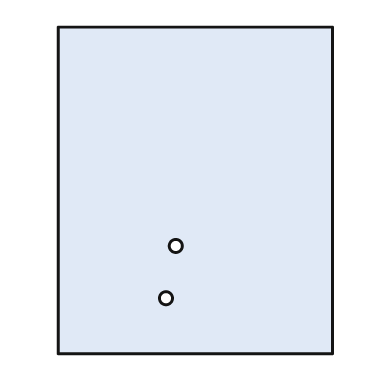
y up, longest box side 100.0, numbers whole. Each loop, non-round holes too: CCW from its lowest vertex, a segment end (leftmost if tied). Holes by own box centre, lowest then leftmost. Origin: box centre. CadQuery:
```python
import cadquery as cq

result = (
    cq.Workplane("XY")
    .moveTo(-42.0, -50.0)
    .lineTo(42.0, -50.0)
    .lineTo(42.0, 50.0)
    .lineTo(-42.0, 50.0)
    .close()
    .moveTo(-9.0, -33.0)
    .circle(2.0)
    .moveTo(-6.0, -17.0)
    .circle(2.0)
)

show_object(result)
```